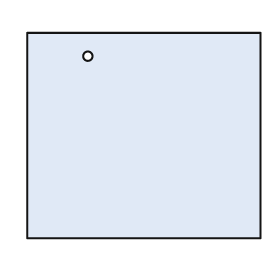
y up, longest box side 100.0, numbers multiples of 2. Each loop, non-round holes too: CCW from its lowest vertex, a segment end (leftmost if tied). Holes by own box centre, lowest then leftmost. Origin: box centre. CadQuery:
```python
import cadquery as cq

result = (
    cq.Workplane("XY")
    .moveTo(-50.0, -44.0)
    .lineTo(50.0, -44.0)
    .lineTo(50.0, 44.0)
    .lineTo(-50.0, 44.0)
    .close()
    .moveTo(-24.0, 34.0)
    .circle(2.0)
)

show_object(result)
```